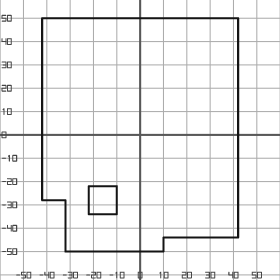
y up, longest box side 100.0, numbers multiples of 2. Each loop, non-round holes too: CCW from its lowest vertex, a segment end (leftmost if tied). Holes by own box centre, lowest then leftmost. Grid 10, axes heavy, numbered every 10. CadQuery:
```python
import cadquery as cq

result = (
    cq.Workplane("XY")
    .moveTo(-32.0, -50.0)
    .lineTo(10.0, -50.0)
    .lineTo(10.0, -44.0)
    .lineTo(42.0, -44.0)
    .lineTo(42.0, 50.0)
    .lineTo(-42.0, 50.0)
    .lineTo(-42.0, -28.0)
    .lineTo(-32.0, -28.0)
    .close()
    .moveTo(-22.0, -34.0)
    .lineTo(-10.0, -34.0)
    .lineTo(-10.0, -22.0)
    .lineTo(-22.0, -22.0)
    .close()
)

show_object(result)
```